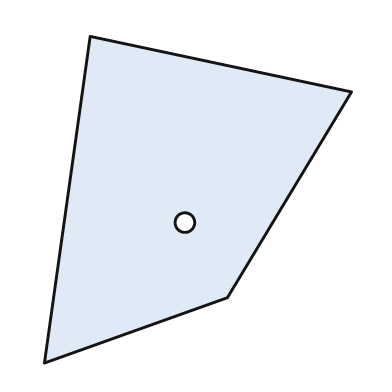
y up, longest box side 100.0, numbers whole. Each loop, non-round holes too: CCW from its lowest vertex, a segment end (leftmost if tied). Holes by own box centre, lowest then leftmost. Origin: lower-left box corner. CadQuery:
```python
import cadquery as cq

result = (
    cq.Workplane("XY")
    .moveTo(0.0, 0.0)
    .lineTo(56.0, 20.0)
    .lineTo(94.0, 83.0)
    .lineTo(14.0, 100.0)
    .close()
    .moveTo(43.0, 43.0)
    .circle(3.0)
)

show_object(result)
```